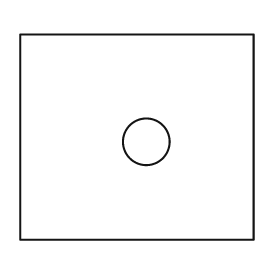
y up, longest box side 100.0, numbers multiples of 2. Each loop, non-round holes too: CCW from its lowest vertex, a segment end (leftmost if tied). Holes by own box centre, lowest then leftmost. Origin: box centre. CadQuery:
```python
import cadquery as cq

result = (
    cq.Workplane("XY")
    .moveTo(-50.0, -44.0)
    .lineTo(50.0, -44.0)
    .lineTo(50.0, 44.0)
    .lineTo(-50.0, 44.0)
    .close()
    .moveTo(4.0, -2.0)
    .circle(10.0)
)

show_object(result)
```